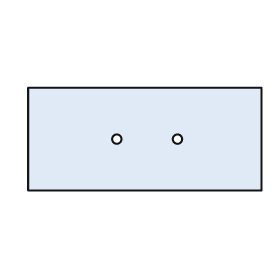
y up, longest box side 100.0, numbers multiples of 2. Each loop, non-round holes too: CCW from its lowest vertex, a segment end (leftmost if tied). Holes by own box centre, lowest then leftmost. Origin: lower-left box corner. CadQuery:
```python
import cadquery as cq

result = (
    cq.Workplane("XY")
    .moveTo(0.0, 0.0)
    .lineTo(100.0, 0.0)
    .lineTo(100.0, 44.0)
    .lineTo(0.0, 44.0)
    .close()
    .moveTo(38.0, 22.0)
    .circle(2.0)
    .moveTo(64.0, 22.0)
    .circle(2.0)
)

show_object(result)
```